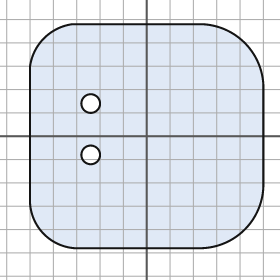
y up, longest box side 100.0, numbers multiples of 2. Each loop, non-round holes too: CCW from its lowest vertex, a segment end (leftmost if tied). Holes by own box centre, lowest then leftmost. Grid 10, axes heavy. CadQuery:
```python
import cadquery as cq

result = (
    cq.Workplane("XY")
    .moveTo(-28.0, -48.0)
    .lineTo(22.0, -48.0)
    .threePointArc((42.0, -40.0), (50.0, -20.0))
    .lineTo(50.0, 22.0)
    .threePointArc((42.0, 40.0), (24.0, 48.0))
    .lineTo(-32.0, 48.0)
    .threePointArc((-44.0, 42.0), (-50.0, 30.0))
    .lineTo(-50.0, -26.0)
    .threePointArc((-44.0, -42.0), (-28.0, -48.0))
    .close()
    .moveTo(-24.0, -8.0)
    .circle(4.0)
    .moveTo(-24.0, 14.0)
    .circle(4.0)
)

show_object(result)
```